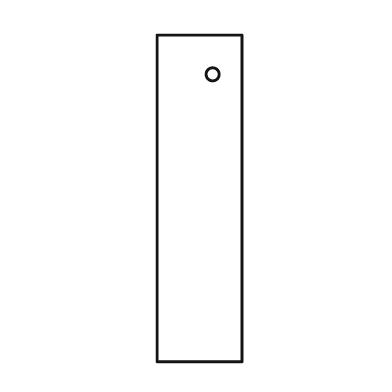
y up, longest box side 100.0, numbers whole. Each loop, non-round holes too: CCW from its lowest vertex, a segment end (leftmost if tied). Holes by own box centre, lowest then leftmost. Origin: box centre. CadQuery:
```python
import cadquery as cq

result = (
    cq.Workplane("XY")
    .moveTo(-13.0, -50.0)
    .lineTo(13.0, -50.0)
    .lineTo(13.0, 50.0)
    .lineTo(-13.0, 50.0)
    .close()
    .moveTo(4.0, 38.0)
    .circle(2.0)
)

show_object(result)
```